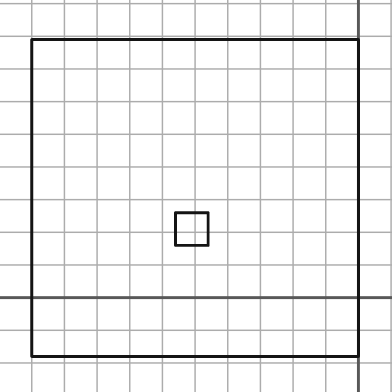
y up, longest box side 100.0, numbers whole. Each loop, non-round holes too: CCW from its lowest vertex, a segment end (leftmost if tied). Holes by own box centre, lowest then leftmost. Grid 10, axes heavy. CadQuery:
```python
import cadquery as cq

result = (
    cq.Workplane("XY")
    .moveTo(-100.0, -18.0)
    .lineTo(0.0, -18.0)
    .lineTo(0.0, 79.0)
    .lineTo(-100.0, 79.0)
    .close()
    .moveTo(-56.0, 16.0)
    .lineTo(-46.0, 16.0)
    .lineTo(-46.0, 26.0)
    .lineTo(-56.0, 26.0)
    .close()
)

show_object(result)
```